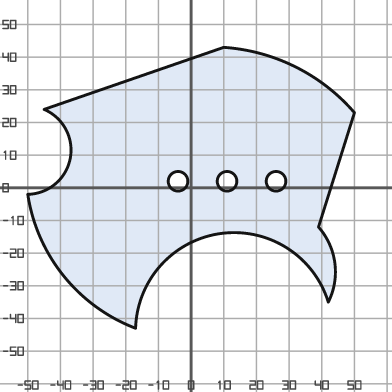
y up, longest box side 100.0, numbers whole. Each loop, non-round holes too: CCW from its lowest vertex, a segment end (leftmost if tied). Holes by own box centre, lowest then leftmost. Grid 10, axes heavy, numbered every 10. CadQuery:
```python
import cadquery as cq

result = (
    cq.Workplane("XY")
    .moveTo(-17.0, -43.0)
    .threePointArc((9.0, -14.0), (42.0, -35.0))
    .threePointArc((44.0, -23.0), (39.0, -12.0))
    .lineTo(50.0, 23.0)
    .threePointArc((32.0, 37.0), (10.0, 43.0))
    .lineTo(-45.0, 24.0)
    .threePointArc((-37.0, 9.0), (-50.0, -2.0))
    .threePointArc((-39.0, -27.0), (-17.0, -43.0))
    .close()
    .moveTo(-4.0, 2.0)
    .circle(3.0)
    .moveTo(11.0, 2.0)
    .circle(3.0)
    .moveTo(26.0, 2.0)
    .circle(3.0)
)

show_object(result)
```